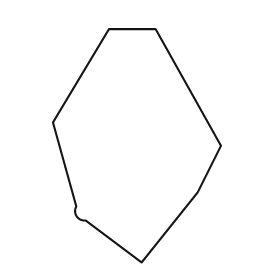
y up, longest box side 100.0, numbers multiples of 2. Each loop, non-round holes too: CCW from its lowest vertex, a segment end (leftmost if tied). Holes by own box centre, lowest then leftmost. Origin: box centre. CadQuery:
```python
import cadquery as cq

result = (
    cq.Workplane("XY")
    .moveTo(2.0, -50.0)
    .lineTo(26.0, -20.0)
    .lineTo(36.0, 0.0)
    .lineTo(8.0, 50.0)
    .lineTo(-12.0, 50.0)
    .lineTo(-36.0, 10.0)
    .lineTo(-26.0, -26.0)
    .threePointArc((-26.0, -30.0), (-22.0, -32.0))
    .close()
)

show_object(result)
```